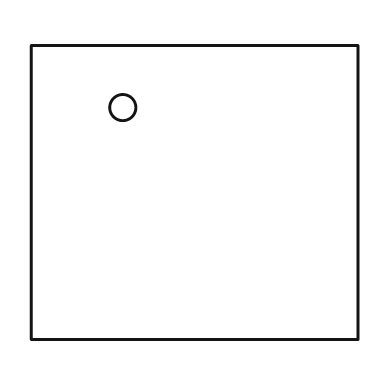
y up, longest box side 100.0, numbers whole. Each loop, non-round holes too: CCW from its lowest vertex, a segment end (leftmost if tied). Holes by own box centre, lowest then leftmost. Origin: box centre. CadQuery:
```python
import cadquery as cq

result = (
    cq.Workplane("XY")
    .moveTo(-50.0, -45.0)
    .lineTo(50.0, -45.0)
    .lineTo(50.0, 45.0)
    .lineTo(-50.0, 45.0)
    .close()
    .moveTo(-22.0, 26.0)
    .circle(4.0)
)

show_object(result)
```